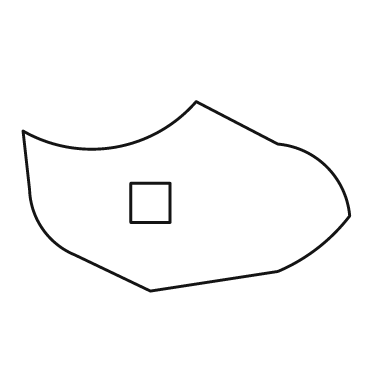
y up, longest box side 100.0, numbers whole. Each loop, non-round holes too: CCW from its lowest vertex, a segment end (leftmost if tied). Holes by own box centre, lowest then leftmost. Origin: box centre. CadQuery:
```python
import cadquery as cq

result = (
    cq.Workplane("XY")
    .moveTo(-11.0, -29.0)
    .lineTo(28.0, -23.0)
    .threePointArc((40.0, -16.0), (50.0, -6.0))
    .threePointArc((43.0, 9.0), (28.0, 16.0))
    .lineTo(3.0, 29.0)
    .threePointArc((-22.0, 15.0), (-50.0, 20.0))
    .lineTo(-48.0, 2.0)
    .threePointArc((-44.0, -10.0), (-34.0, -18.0))
    .close()
    .moveTo(-17.0, -8.0)
    .lineTo(-5.0, -8.0)
    .lineTo(-5.0, 4.0)
    .lineTo(-17.0, 4.0)
    .close()
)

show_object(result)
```